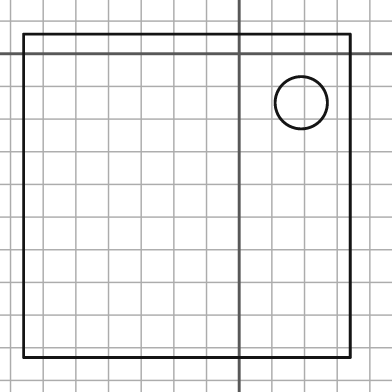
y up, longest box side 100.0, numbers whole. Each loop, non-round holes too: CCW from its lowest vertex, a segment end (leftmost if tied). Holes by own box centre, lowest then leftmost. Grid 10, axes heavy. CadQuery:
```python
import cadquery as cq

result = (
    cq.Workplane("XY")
    .moveTo(-66.0, -93.0)
    .lineTo(34.0, -93.0)
    .lineTo(34.0, 6.0)
    .lineTo(-66.0, 6.0)
    .close()
    .moveTo(19.0, -15.0)
    .circle(8.0)
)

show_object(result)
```